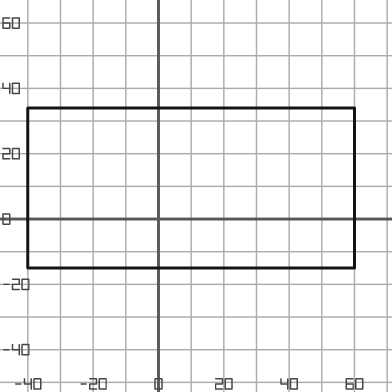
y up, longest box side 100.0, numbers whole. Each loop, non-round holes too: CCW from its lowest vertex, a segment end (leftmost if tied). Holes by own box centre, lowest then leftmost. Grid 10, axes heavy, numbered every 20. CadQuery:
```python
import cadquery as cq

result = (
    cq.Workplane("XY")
    .moveTo(-40.0, -15.0)
    .lineTo(60.0, -15.0)
    .lineTo(60.0, 34.0)
    .lineTo(-40.0, 34.0)
    .close()
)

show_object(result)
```